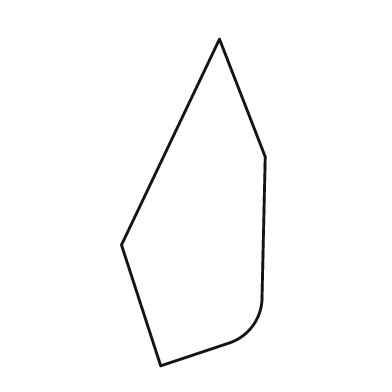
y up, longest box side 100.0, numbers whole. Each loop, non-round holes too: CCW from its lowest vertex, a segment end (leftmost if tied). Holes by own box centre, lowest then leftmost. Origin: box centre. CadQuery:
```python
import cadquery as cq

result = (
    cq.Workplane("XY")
    .moveTo(-10.0, -50.0)
    .lineTo(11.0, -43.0)
    .threePointArc((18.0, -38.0), (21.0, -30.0))
    .lineTo(22.0, 14.0)
    .lineTo(8.0, 50.0)
    .lineTo(-22.0, -13.0)
    .close()
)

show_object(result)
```